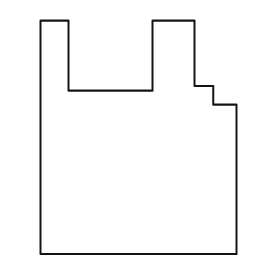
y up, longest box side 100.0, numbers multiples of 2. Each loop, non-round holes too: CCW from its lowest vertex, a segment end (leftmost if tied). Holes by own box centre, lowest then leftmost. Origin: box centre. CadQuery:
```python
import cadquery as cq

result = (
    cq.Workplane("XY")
    .moveTo(-42.0, -50.0)
    .lineTo(42.0, -50.0)
    .lineTo(42.0, 14.0)
    .lineTo(32.0, 14.0)
    .lineTo(32.0, 22.0)
    .lineTo(24.0, 22.0)
    .lineTo(24.0, 50.0)
    .lineTo(6.0, 50.0)
    .lineTo(6.0, 20.0)
    .lineTo(-30.0, 20.0)
    .lineTo(-30.0, 50.0)
    .lineTo(-42.0, 50.0)
    .close()
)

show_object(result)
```